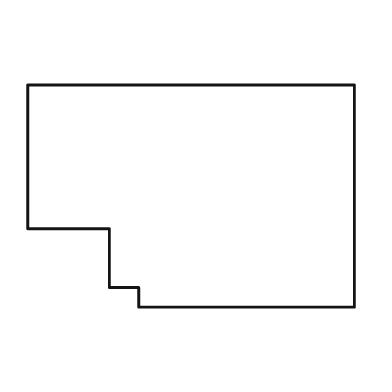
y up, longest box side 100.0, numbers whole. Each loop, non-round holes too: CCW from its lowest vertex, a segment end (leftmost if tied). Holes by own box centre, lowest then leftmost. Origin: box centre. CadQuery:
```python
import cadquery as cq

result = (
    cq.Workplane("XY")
    .moveTo(-16.0, -34.0)
    .lineTo(50.0, -34.0)
    .lineTo(50.0, 34.0)
    .lineTo(-50.0, 34.0)
    .lineTo(-50.0, -10.0)
    .lineTo(-25.0, -10.0)
    .lineTo(-25.0, -28.0)
    .lineTo(-16.0, -28.0)
    .close()
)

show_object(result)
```